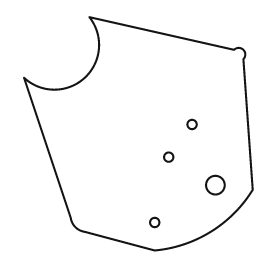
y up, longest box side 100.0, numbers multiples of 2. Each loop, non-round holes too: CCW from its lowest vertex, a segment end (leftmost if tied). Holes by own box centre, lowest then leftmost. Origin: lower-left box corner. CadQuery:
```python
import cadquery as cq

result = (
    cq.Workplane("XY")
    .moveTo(56.0, 0.0)
    .threePointArc((80.0, 8.0), (98.0, 26.0))
    .lineTo(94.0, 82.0)
    .threePointArc((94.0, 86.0), (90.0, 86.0))
    .lineTo(28.0, 100.0)
    .threePointArc((26.0, 74.0), (0.0, 74.0))
    .lineTo(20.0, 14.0)
    .threePointArc((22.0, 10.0), (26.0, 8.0))
    .close()
    .moveTo(56.0, 12.0)
    .circle(2.0)
    .moveTo(82.0, 28.0)
    .circle(4.0)
    .moveTo(62.0, 40.0)
    .circle(2.0)
    .moveTo(72.0, 54.0)
    .circle(2.0)
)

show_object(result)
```